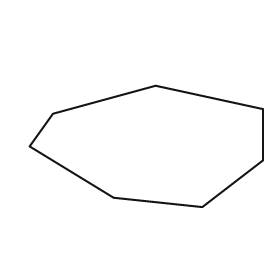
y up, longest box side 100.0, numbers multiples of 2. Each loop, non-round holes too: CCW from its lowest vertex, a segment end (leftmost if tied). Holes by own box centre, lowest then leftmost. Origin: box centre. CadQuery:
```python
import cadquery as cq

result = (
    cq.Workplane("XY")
    .moveTo(24.0, -26.0)
    .lineTo(50.0, -6.0)
    .lineTo(50.0, 16.0)
    .lineTo(4.0, 26.0)
    .lineTo(-40.0, 14.0)
    .lineTo(-50.0, 0.0)
    .lineTo(-14.0, -22.0)
    .close()
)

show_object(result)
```